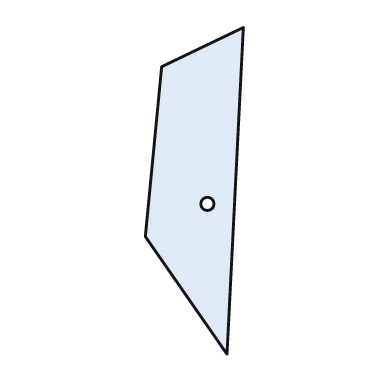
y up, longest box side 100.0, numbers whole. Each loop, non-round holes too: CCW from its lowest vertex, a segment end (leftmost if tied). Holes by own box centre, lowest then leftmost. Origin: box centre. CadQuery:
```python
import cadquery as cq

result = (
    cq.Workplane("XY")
    .moveTo(10.0, -50.0)
    .lineTo(15.0, 50.0)
    .lineTo(-10.0, 38.0)
    .lineTo(-15.0, -14.0)
    .close()
    .moveTo(4.0, -4.0)
    .circle(2.0)
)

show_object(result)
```